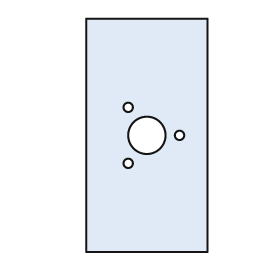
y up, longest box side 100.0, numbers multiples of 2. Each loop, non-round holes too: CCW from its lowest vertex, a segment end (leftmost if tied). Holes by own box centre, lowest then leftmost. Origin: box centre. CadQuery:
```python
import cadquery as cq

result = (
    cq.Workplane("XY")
    .moveTo(-26.0, -50.0)
    .lineTo(26.0, -50.0)
    .lineTo(26.0, 50.0)
    .lineTo(-26.0, 50.0)
    .close()
    .moveTo(-8.0, -12.0)
    .circle(2.0)
    .moveTo(0.0, 0.0)
    .circle(8.0)
    .moveTo(14.0, 0.0)
    .circle(2.0)
    .moveTo(-8.0, 12.0)
    .circle(2.0)
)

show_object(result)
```